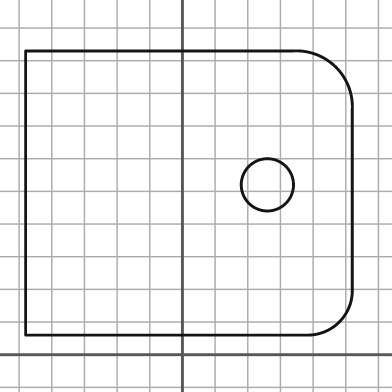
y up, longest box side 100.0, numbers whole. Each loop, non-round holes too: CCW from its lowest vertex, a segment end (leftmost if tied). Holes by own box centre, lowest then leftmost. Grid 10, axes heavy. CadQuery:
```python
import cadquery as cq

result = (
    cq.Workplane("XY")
    .moveTo(-48.0, 6.0)
    .lineTo(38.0, 6.0)
    .threePointArc((48.0, 10.0), (52.0, 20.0))
    .lineTo(52.0, 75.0)
    .threePointArc((47.0, 88.0), (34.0, 93.0))
    .lineTo(-48.0, 93.0)
    .close()
    .moveTo(26.0, 52.0)
    .circle(8.0)
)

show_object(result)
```